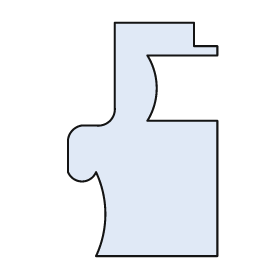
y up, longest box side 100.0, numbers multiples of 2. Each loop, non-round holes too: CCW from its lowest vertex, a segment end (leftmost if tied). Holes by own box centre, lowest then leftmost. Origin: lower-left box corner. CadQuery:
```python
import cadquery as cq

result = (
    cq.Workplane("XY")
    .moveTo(12.0, 0.0)
    .lineTo(64.0, 0.0)
    .lineTo(64.0, 58.0)
    .lineTo(34.0, 58.0)
    .threePointArc((38.0, 72.0), (34.0, 86.0))
    .lineTo(64.0, 86.0)
    .lineTo(64.0, 90.0)
    .lineTo(54.0, 90.0)
    .lineTo(54.0, 100.0)
    .lineTo(20.0, 100.0)
    .lineTo(20.0, 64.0)
    .threePointArc((18.0, 58.0), (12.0, 56.0))
    .lineTo(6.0, 56.0)
    .threePointArc((2.0, 54.0), (0.0, 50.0))
    .lineTo(0.0, 36.0)
    .threePointArc((6.0, 32.0), (12.0, 36.0))
    .threePointArc((16.0, 18.0), (12.0, 0.0))
    .close()
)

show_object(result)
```